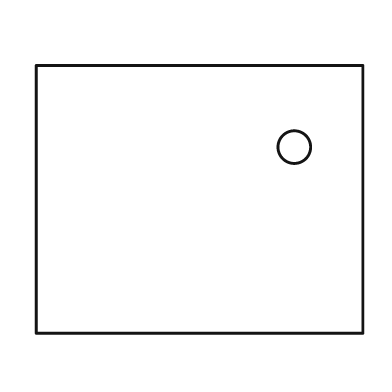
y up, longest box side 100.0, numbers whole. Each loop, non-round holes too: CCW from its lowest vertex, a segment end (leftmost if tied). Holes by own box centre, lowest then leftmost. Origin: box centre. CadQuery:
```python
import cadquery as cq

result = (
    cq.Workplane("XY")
    .moveTo(-50.0, -41.0)
    .lineTo(50.0, -41.0)
    .lineTo(50.0, 41.0)
    .lineTo(-50.0, 41.0)
    .close()
    .moveTo(29.0, 16.0)
    .circle(5.0)
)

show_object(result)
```